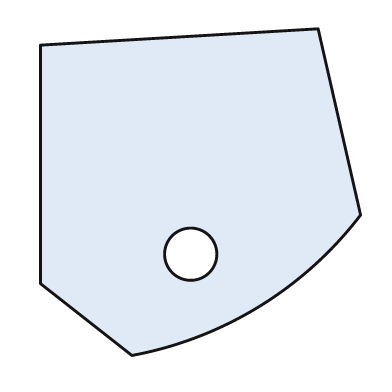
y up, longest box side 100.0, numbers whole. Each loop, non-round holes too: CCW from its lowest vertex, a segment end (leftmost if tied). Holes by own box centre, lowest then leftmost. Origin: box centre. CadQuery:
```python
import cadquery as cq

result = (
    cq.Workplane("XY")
    .moveTo(-21.0, -50.0)
    .threePointArc((18.0, -35.0), (49.0, -7.0))
    .lineTo(36.0, 50.0)
    .lineTo(-49.0, 45.0)
    .lineTo(-49.0, -28.0)
    .close()
    .moveTo(-3.0, -19.0)
    .circle(8.0)
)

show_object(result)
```